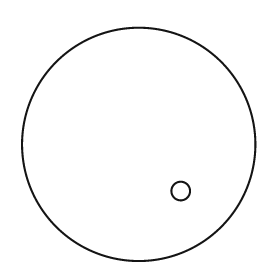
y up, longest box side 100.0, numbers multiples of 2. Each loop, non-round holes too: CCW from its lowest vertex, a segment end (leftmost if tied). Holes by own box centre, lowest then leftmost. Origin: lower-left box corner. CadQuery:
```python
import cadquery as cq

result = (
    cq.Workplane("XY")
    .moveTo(50.0, 50.0)
    .circle(50.0)
    .moveTo(68.0, 30.0)
    .circle(4.0)
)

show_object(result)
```